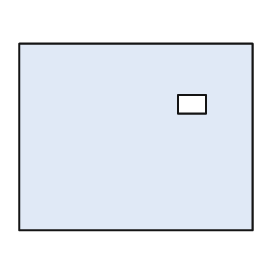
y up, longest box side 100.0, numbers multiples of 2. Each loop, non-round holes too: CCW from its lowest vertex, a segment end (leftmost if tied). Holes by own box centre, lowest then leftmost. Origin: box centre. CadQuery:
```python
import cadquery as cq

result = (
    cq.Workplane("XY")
    .moveTo(-50.0, -40.0)
    .lineTo(50.0, -40.0)
    .lineTo(50.0, 40.0)
    .lineTo(-50.0, 40.0)
    .close()
    .moveTo(18.0, 10.0)
    .lineTo(30.0, 10.0)
    .lineTo(30.0, 18.0)
    .lineTo(18.0, 18.0)
    .close()
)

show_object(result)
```